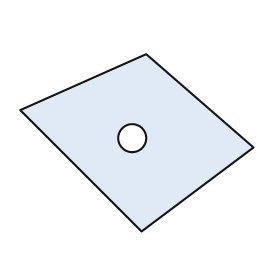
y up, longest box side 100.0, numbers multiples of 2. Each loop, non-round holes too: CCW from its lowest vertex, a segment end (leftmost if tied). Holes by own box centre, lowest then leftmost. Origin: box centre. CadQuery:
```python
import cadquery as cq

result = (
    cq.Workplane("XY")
    .moveTo(2.0, -38.0)
    .lineTo(50.0, -2.0)
    .lineTo(4.0, 38.0)
    .lineTo(-50.0, 14.0)
    .close()
    .moveTo(-2.0, 2.0)
    .circle(6.0)
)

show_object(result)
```